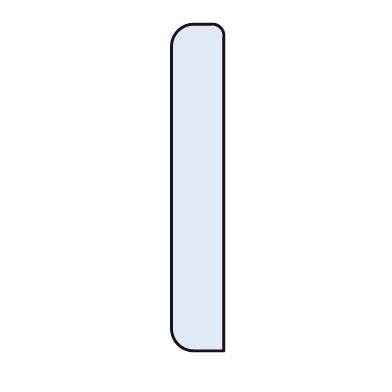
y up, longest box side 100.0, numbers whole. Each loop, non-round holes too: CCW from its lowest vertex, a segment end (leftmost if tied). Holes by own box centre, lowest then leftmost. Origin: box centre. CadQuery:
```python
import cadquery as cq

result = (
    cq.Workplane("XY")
    .moveTo(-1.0, -50.0)
    .lineTo(8.0, -50.0)
    .lineTo(8.0, 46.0)
    .threePointArc((7.0, 49.0), (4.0, 50.0))
    .lineTo(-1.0, 50.0)
    .threePointArc((-6.0, 48.0), (-8.0, 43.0))
    .lineTo(-8.0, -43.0)
    .threePointArc((-6.0, -48.0), (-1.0, -50.0))
    .close()
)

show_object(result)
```